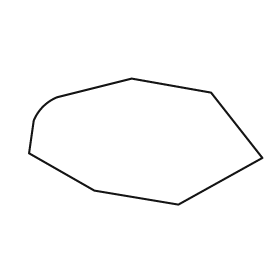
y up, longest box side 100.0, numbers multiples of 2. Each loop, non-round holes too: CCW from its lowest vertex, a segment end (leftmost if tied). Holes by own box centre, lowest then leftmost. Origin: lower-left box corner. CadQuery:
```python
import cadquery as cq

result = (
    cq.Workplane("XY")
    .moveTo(64.0, 0.0)
    .lineTo(100.0, 20.0)
    .lineTo(78.0, 48.0)
    .lineTo(44.0, 54.0)
    .lineTo(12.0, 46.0)
    .threePointArc((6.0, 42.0), (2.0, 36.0))
    .lineTo(0.0, 22.0)
    .lineTo(28.0, 6.0)
    .close()
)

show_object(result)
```